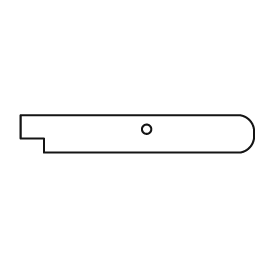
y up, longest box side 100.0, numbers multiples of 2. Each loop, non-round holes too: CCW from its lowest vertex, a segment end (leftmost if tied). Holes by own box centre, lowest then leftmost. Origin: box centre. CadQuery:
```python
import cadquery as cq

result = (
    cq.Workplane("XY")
    .moveTo(-40.0, -8.0)
    .lineTo(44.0, -8.0)
    .threePointArc((48.0, -6.0), (50.0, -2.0))
    .lineTo(50.0, 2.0)
    .threePointArc((48.0, 6.0), (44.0, 8.0))
    .lineTo(-50.0, 8.0)
    .lineTo(-50.0, -2.0)
    .lineTo(-40.0, -2.0)
    .close()
    .moveTo(4.0, 2.0)
    .circle(2.0)
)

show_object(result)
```